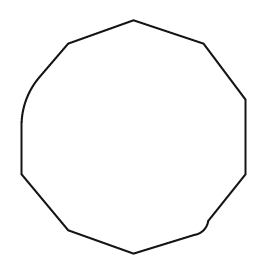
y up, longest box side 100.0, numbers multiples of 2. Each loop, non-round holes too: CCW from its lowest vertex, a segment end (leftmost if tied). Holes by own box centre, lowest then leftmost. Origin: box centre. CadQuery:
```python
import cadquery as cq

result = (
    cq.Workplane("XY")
    .moveTo(0.0, -50.0)
    .lineTo(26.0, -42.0)
    .threePointArc((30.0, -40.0), (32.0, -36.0))
    .lineTo(48.0, -16.0)
    .lineTo(48.0, 16.0)
    .lineTo(30.0, 40.0)
    .lineTo(0.0, 50.0)
    .lineTo(-28.0, 40.0)
    .lineTo(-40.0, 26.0)
    .threePointArc((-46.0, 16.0), (-48.0, 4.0))
    .lineTo(-48.0, -16.0)
    .lineTo(-28.0, -40.0)
    .close()
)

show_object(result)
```